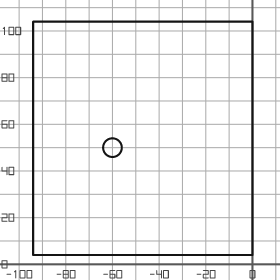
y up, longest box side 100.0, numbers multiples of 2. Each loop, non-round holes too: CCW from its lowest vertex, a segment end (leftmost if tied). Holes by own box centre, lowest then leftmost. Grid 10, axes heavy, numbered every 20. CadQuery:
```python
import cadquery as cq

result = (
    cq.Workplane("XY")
    .moveTo(-94.0, 4.0)
    .lineTo(0.0, 4.0)
    .lineTo(0.0, 104.0)
    .lineTo(-94.0, 104.0)
    .close()
    .moveTo(-60.0, 50.0)
    .circle(4.0)
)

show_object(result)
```